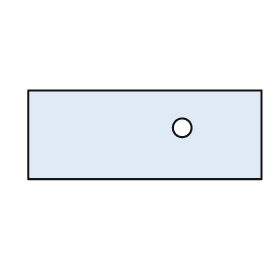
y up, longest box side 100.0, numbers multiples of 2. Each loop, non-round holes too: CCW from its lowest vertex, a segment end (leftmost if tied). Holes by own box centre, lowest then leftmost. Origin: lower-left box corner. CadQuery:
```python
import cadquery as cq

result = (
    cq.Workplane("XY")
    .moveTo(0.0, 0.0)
    .lineTo(100.0, 0.0)
    .lineTo(100.0, 38.0)
    .lineTo(0.0, 38.0)
    .close()
    .moveTo(66.0, 22.0)
    .circle(4.0)
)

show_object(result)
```